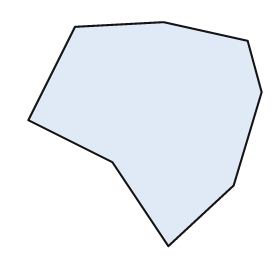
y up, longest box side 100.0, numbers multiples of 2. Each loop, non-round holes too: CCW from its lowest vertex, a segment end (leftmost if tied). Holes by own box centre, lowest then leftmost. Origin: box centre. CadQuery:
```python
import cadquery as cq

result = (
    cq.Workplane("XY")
    .moveTo(10.0, -48.0)
    .lineTo(38.0, -22.0)
    .lineTo(50.0, 18.0)
    .lineTo(44.0, 40.0)
    .lineTo(8.0, 48.0)
    .lineTo(-30.0, 46.0)
    .lineTo(-50.0, 6.0)
    .lineTo(-14.0, -12.0)
    .close()
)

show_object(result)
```